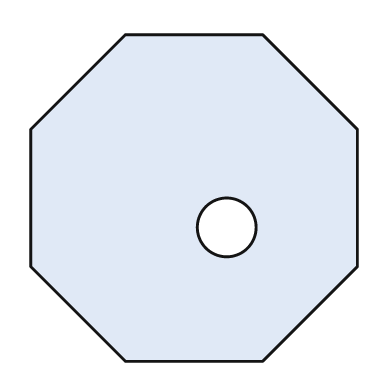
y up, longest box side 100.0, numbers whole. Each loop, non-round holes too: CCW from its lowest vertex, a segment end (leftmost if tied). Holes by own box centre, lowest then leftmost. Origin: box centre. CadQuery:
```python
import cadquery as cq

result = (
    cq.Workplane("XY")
    .moveTo(-21.0, -50.0)
    .lineTo(21.0, -50.0)
    .lineTo(50.0, -21.0)
    .lineTo(50.0, 21.0)
    .lineTo(21.0, 50.0)
    .lineTo(-21.0, 50.0)
    .lineTo(-50.0, 21.0)
    .lineTo(-50.0, -21.0)
    .close()
    .moveTo(10.0, -9.0)
    .circle(9.0)
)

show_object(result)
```